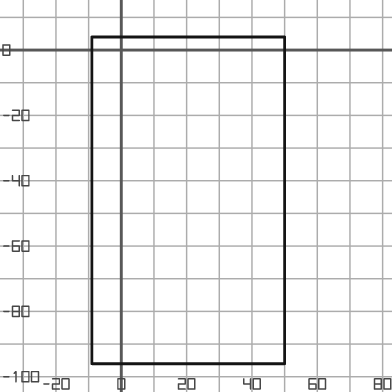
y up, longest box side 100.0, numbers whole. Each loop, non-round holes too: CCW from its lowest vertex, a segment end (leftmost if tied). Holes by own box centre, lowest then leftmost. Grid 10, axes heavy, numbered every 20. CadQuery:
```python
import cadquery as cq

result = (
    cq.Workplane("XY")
    .moveTo(-9.0, -96.0)
    .lineTo(50.0, -96.0)
    .lineTo(50.0, 4.0)
    .lineTo(-9.0, 4.0)
    .close()
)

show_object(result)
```